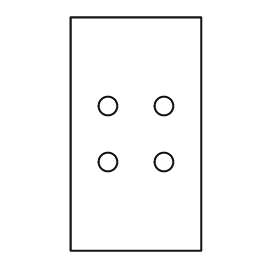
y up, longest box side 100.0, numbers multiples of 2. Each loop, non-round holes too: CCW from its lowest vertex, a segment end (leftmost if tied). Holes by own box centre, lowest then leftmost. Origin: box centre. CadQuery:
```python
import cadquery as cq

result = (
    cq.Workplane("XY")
    .moveTo(-28.0, -50.0)
    .lineTo(28.0, -50.0)
    .lineTo(28.0, 50.0)
    .lineTo(-28.0, 50.0)
    .close()
    .moveTo(-12.0, -12.0)
    .circle(4.0)
    .moveTo(12.0, -12.0)
    .circle(4.0)
    .moveTo(-12.0, 12.0)
    .circle(4.0)
    .moveTo(12.0, 12.0)
    .circle(4.0)
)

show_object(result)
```